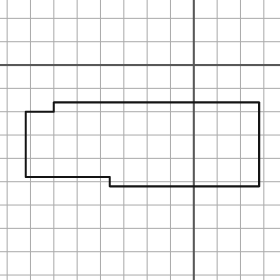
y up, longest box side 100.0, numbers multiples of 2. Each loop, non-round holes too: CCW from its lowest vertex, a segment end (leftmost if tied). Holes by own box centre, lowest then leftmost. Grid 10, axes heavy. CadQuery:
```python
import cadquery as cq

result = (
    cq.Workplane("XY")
    .moveTo(-36.0, -52.0)
    .lineTo(28.0, -52.0)
    .lineTo(28.0, -16.0)
    .lineTo(-60.0, -16.0)
    .lineTo(-60.0, -20.0)
    .lineTo(-72.0, -20.0)
    .lineTo(-72.0, -48.0)
    .lineTo(-36.0, -48.0)
    .close()
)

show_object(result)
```